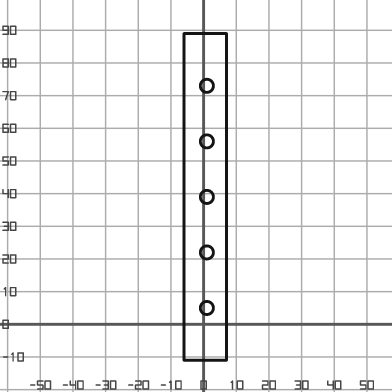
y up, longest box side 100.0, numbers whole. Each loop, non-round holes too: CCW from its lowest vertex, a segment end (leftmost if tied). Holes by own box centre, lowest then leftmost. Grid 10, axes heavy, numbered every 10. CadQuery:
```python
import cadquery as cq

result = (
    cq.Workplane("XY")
    .moveTo(-6.0, -11.0)
    .lineTo(7.0, -11.0)
    .lineTo(7.0, 89.0)
    .lineTo(-6.0, 89.0)
    .close()
    .moveTo(1.0, 5.0)
    .circle(2.0)
    .moveTo(1.0, 22.0)
    .circle(2.0)
    .moveTo(1.0, 39.0)
    .circle(2.0)
    .moveTo(1.0, 56.0)
    .circle(2.0)
    .moveTo(1.0, 73.0)
    .circle(2.0)
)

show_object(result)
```